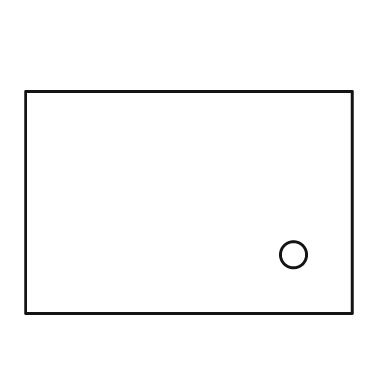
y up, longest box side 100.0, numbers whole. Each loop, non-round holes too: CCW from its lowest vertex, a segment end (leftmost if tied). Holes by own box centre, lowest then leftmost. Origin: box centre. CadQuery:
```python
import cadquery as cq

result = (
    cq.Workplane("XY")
    .moveTo(-50.0, -34.0)
    .lineTo(50.0, -34.0)
    .lineTo(50.0, 34.0)
    .lineTo(-50.0, 34.0)
    .close()
    .moveTo(32.0, -16.0)
    .circle(4.0)
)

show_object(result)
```